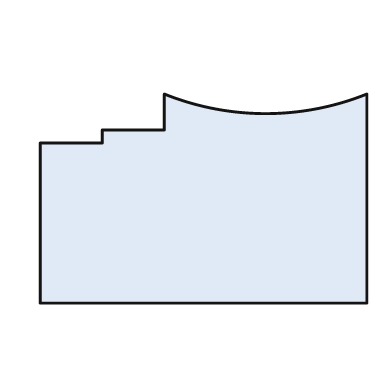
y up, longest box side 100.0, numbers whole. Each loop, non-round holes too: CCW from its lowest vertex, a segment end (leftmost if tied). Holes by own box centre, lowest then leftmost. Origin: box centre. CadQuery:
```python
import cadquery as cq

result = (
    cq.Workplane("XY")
    .moveTo(-50.0, -32.0)
    .lineTo(50.0, -32.0)
    .lineTo(50.0, 32.0)
    .threePointArc((19.0, 26.0), (-12.0, 32.0))
    .lineTo(-12.0, 21.0)
    .lineTo(-31.0, 21.0)
    .lineTo(-31.0, 17.0)
    .lineTo(-50.0, 17.0)
    .close()
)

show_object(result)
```